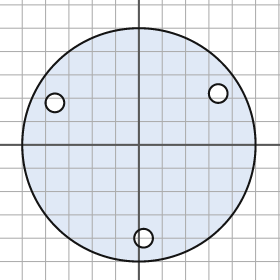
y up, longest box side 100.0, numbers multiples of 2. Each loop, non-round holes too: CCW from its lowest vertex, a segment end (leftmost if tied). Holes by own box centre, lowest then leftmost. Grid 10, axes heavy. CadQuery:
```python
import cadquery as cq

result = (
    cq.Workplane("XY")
    .moveTo(0.0, 0.0)
    .circle(50.0)
    .moveTo(2.0, -40.0)
    .circle(4.0)
    .moveTo(-36.0, 18.0)
    .circle(4.0)
    .moveTo(34.0, 22.0)
    .circle(4.0)
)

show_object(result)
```